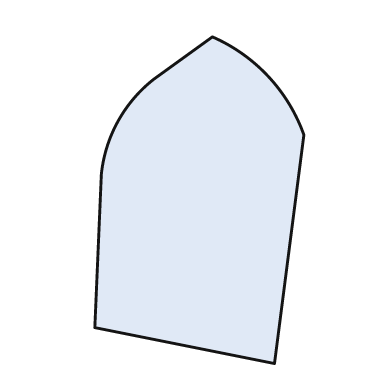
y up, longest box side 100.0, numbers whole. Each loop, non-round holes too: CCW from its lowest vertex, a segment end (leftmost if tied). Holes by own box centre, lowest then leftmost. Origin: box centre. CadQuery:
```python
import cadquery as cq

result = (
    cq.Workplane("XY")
    .moveTo(23.0, -50.0)
    .lineTo(32.0, 20.0)
    .threePointArc((21.0, 38.0), (4.0, 50.0))
    .lineTo(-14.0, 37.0)
    .threePointArc((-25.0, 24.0), (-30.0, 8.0))
    .lineTo(-32.0, -39.0)
    .close()
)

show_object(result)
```